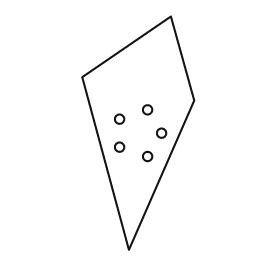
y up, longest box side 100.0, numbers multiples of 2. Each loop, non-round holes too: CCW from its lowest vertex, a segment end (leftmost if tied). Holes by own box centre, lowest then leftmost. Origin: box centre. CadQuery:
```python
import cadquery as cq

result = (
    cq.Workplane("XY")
    .moveTo(-4.0, -50.0)
    .lineTo(24.0, 14.0)
    .lineTo(14.0, 50.0)
    .lineTo(-24.0, 24.0)
    .close()
    .moveTo(4.0, -10.0)
    .circle(2.0)
    .moveTo(-8.0, -6.0)
    .circle(2.0)
    .moveTo(10.0, 0.0)
    .circle(2.0)
    .moveTo(-8.0, 6.0)
    .circle(2.0)
    .moveTo(4.0, 10.0)
    .circle(2.0)
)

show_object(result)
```